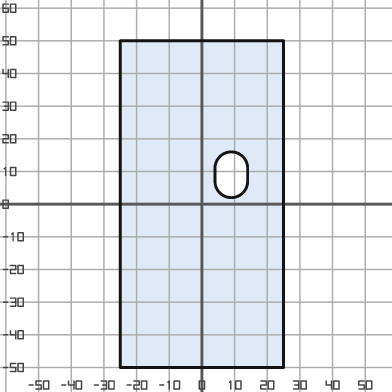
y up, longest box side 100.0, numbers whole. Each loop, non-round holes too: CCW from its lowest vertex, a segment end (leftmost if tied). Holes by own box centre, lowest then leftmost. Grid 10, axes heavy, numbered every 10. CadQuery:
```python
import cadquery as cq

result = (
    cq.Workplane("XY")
    .moveTo(-25.0, -50.0)
    .lineTo(25.0, -50.0)
    .lineTo(25.0, 50.0)
    .lineTo(-25.0, 50.0)
    .close()
    .moveTo(4.0, 7.0)
    .threePointArc((9.0, 2.0), (14.0, 7.0))
    .lineTo(14.0, 11.0)
    .threePointArc((9.0, 16.0), (4.0, 11.0))
    .close()
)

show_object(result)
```